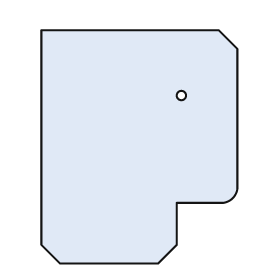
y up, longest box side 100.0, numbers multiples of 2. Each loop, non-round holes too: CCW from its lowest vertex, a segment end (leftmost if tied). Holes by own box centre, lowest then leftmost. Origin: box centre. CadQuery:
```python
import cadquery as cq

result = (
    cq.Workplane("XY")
    .moveTo(-34.0, -50.0)
    .lineTo(8.0, -50.0)
    .lineTo(16.0, -42.0)
    .lineTo(16.0, -24.0)
    .lineTo(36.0, -24.0)
    .threePointArc((40.0, -22.0), (42.0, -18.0))
    .lineTo(42.0, 42.0)
    .lineTo(34.0, 50.0)
    .lineTo(-42.0, 50.0)
    .lineTo(-42.0, -42.0)
    .close()
    .moveTo(18.0, 22.0)
    .circle(2.0)
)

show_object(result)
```